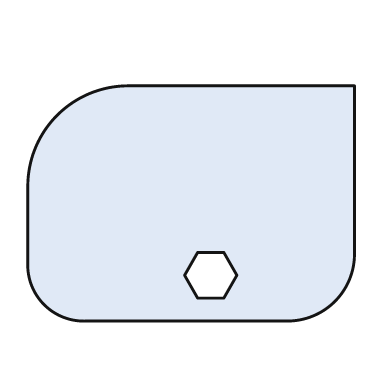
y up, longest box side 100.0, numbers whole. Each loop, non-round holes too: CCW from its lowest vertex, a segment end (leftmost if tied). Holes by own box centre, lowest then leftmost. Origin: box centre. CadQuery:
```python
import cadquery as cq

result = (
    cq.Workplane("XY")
    .moveTo(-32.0, -36.0)
    .lineTo(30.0, -36.0)
    .threePointArc((44.0, -30.0), (50.0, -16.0))
    .lineTo(50.0, 36.0)
    .lineTo(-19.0, 36.0)
    .threePointArc((-41.0, 27.0), (-50.0, 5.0))
    .lineTo(-50.0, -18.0)
    .threePointArc((-45.0, -31.0), (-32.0, -36.0))
    .close()
    .moveTo(2.0, -29.0)
    .lineTo(10.0, -29.0)
    .lineTo(14.0, -22.0)
    .lineTo(10.0, -15.0)
    .lineTo(2.0, -15.0)
    .lineTo(-2.0, -22.0)
    .close()
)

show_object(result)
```